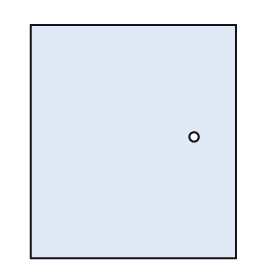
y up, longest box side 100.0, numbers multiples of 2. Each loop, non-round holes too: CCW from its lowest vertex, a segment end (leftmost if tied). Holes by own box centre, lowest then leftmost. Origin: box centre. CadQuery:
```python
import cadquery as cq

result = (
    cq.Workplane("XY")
    .moveTo(-44.0, -50.0)
    .lineTo(44.0, -50.0)
    .lineTo(44.0, 50.0)
    .lineTo(-44.0, 50.0)
    .close()
    .moveTo(26.0, 2.0)
    .circle(2.0)
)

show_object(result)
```